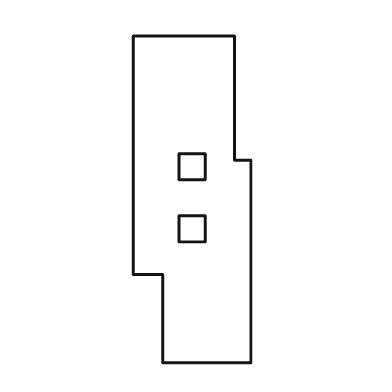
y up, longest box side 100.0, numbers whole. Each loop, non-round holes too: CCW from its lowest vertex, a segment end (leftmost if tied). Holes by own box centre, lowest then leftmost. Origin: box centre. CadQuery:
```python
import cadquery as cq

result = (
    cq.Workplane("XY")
    .moveTo(-9.0, -50.0)
    .lineTo(18.0, -50.0)
    .lineTo(18.0, 12.0)
    .lineTo(13.0, 12.0)
    .lineTo(13.0, 50.0)
    .lineTo(-18.0, 50.0)
    .lineTo(-18.0, -23.0)
    .lineTo(-9.0, -23.0)
    .close()
    .moveTo(-4.0, -13.0)
    .lineTo(4.0, -13.0)
    .lineTo(4.0, -5.0)
    .lineTo(-4.0, -5.0)
    .close()
    .moveTo(-4.0, 6.0)
    .lineTo(4.0, 6.0)
    .lineTo(4.0, 14.0)
    .lineTo(-4.0, 14.0)
    .close()
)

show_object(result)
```